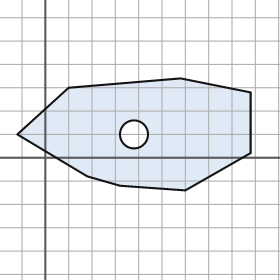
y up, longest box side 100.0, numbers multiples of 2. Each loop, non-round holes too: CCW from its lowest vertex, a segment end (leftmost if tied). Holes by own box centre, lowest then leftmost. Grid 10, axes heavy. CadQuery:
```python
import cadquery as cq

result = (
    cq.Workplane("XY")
    .moveTo(60.0, -14.0)
    .lineTo(88.0, 2.0)
    .lineTo(88.0, 28.0)
    .lineTo(58.0, 34.0)
    .lineTo(10.0, 30.0)
    .lineTo(-12.0, 10.0)
    .lineTo(18.0, -8.0)
    .lineTo(32.0, -12.0)
    .close()
    .moveTo(38.0, 10.0)
    .circle(6.0)
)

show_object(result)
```